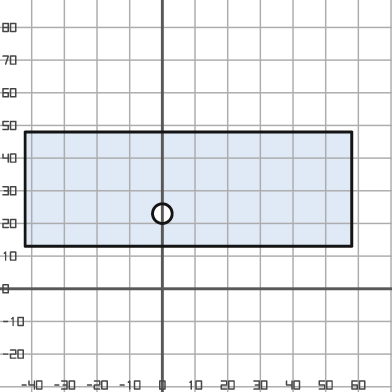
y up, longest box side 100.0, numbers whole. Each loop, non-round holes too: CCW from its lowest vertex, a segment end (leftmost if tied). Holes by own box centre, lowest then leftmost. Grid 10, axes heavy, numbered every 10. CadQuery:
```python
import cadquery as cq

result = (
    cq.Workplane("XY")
    .moveTo(-42.0, 13.0)
    .lineTo(58.0, 13.0)
    .lineTo(58.0, 48.0)
    .lineTo(-42.0, 48.0)
    .close()
    .moveTo(0.0, 23.0)
    .circle(3.0)
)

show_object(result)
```